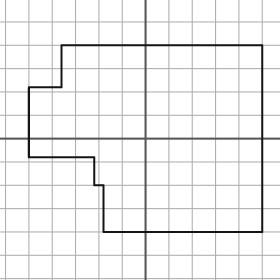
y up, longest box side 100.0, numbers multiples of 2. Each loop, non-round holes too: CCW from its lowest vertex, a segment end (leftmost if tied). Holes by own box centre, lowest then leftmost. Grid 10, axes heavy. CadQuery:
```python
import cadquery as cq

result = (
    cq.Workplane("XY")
    .moveTo(-18.0, -40.0)
    .lineTo(50.0, -40.0)
    .lineTo(50.0, 40.0)
    .lineTo(-36.0, 40.0)
    .lineTo(-36.0, 22.0)
    .lineTo(-50.0, 22.0)
    .lineTo(-50.0, -8.0)
    .lineTo(-22.0, -8.0)
    .lineTo(-22.0, -20.0)
    .lineTo(-18.0, -20.0)
    .close()
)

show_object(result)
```